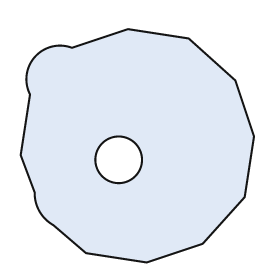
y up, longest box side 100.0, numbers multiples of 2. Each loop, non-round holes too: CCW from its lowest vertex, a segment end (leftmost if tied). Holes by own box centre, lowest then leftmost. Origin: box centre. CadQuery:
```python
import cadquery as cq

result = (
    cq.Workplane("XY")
    .moveTo(4.0, -50.0)
    .lineTo(28.0, -42.0)
    .lineTo(46.0, -22.0)
    .lineTo(50.0, 4.0)
    .lineTo(42.0, 28.0)
    .lineTo(22.0, 46.0)
    .lineTo(-4.0, 50.0)
    .lineTo(-28.0, 42.0)
    .threePointArc((-44.0, 38.0), (-46.0, 22.0))
    .lineTo(-50.0, -4.0)
    .lineTo(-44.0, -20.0)
    .threePointArc((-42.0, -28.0), (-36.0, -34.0))
    .lineTo(-22.0, -46.0)
    .close()
    .moveTo(-8.0, -6.0)
    .circle(10.0)
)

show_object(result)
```